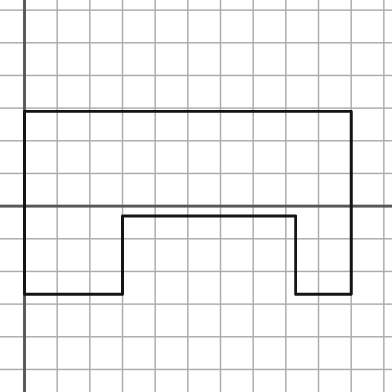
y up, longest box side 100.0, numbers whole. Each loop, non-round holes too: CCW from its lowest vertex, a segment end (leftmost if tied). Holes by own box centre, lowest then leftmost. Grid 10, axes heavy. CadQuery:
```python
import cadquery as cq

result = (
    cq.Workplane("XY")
    .moveTo(0.0, -27.0)
    .lineTo(30.0, -27.0)
    .lineTo(30.0, -3.0)
    .lineTo(83.0, -3.0)
    .lineTo(83.0, -27.0)
    .lineTo(100.0, -27.0)
    .lineTo(100.0, 29.0)
    .lineTo(0.0, 29.0)
    .close()
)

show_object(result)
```